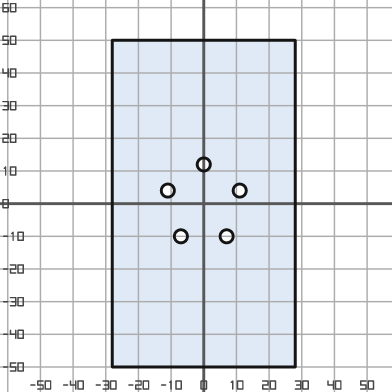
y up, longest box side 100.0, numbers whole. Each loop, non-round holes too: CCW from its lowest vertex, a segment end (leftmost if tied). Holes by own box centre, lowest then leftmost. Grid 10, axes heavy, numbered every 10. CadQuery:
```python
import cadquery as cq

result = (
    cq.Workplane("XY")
    .moveTo(-28.0, -50.0)
    .lineTo(28.0, -50.0)
    .lineTo(28.0, 50.0)
    .lineTo(-28.0, 50.0)
    .close()
    .moveTo(-7.0, -10.0)
    .circle(2.0)
    .moveTo(7.0, -10.0)
    .circle(2.0)
    .moveTo(-11.0, 4.0)
    .circle(2.0)
    .moveTo(11.0, 4.0)
    .circle(2.0)
    .moveTo(0.0, 12.0)
    .circle(2.0)
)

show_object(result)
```